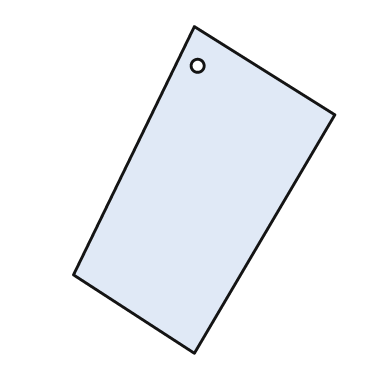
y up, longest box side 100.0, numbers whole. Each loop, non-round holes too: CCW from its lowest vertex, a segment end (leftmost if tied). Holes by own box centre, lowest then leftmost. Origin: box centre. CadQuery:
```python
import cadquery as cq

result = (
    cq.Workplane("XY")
    .moveTo(-3.0, -50.0)
    .lineTo(40.0, 23.0)
    .lineTo(-3.0, 50.0)
    .lineTo(-40.0, -26.0)
    .close()
    .moveTo(-2.0, 38.0)
    .circle(2.0)
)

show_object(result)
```